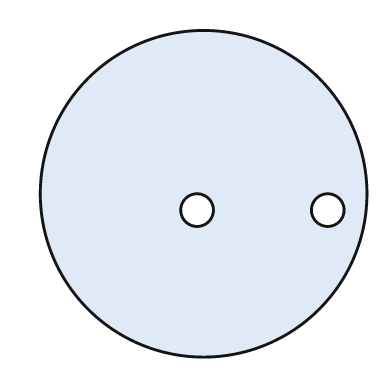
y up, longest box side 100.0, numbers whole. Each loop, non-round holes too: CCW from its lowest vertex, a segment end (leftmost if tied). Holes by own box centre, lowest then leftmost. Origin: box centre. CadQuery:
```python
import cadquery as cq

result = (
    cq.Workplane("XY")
    .moveTo(0.0, 0.0)
    .circle(50.0)
    .moveTo(-2.0, -5.0)
    .circle(5.0)
    .moveTo(38.0, -5.0)
    .circle(5.0)
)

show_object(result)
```